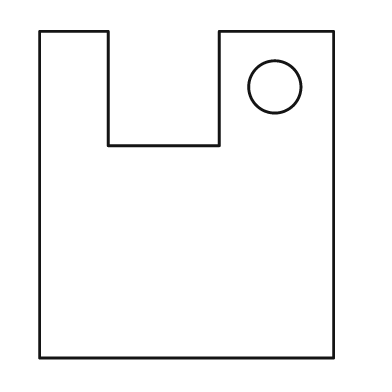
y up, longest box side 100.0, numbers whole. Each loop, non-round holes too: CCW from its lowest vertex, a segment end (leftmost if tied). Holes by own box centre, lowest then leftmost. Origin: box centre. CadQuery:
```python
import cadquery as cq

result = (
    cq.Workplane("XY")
    .moveTo(-45.0, -50.0)
    .lineTo(45.0, -50.0)
    .lineTo(45.0, 50.0)
    .lineTo(10.0, 50.0)
    .lineTo(10.0, 15.0)
    .lineTo(-24.0, 15.0)
    .lineTo(-24.0, 50.0)
    .lineTo(-45.0, 50.0)
    .close()
    .moveTo(27.0, 33.0)
    .circle(8.0)
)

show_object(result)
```